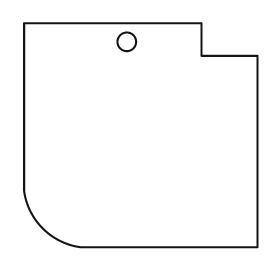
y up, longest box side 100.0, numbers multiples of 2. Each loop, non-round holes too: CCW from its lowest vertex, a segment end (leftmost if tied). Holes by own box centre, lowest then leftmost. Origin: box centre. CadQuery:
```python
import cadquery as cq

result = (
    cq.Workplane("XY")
    .moveTo(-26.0, -48.0)
    .lineTo(50.0, -48.0)
    .lineTo(50.0, 34.0)
    .lineTo(26.0, 34.0)
    .lineTo(26.0, 48.0)
    .lineTo(-50.0, 48.0)
    .lineTo(-50.0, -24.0)
    .threePointArc((-42.0, -40.0), (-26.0, -48.0))
    .close()
    .moveTo(-6.0, 40.0)
    .circle(4.0)
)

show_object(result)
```